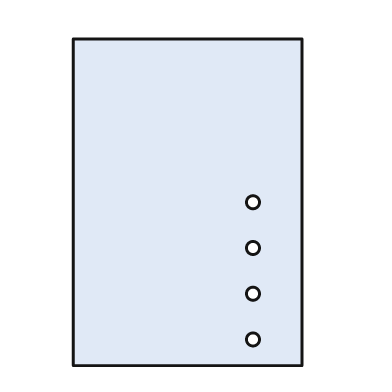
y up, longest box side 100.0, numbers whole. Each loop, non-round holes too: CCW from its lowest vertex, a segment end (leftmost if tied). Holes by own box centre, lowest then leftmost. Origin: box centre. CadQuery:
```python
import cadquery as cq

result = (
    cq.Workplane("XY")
    .moveTo(-35.0, -50.0)
    .lineTo(35.0, -50.0)
    .lineTo(35.0, 50.0)
    .lineTo(-35.0, 50.0)
    .close()
    .moveTo(20.0, -42.0)
    .circle(2.0)
    .moveTo(20.0, -28.0)
    .circle(2.0)
    .moveTo(20.0, -14.0)
    .circle(2.0)
    .moveTo(20.0, 0.0)
    .circle(2.0)
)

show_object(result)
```